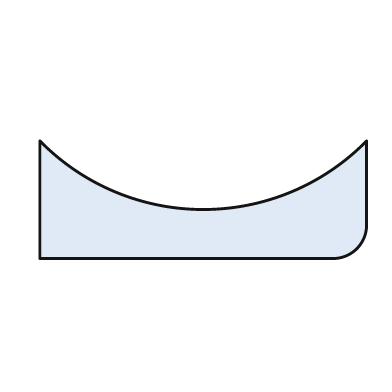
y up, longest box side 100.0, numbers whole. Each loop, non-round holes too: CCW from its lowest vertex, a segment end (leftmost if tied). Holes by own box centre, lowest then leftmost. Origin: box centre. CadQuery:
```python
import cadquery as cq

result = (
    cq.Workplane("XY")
    .moveTo(-50.0, -18.0)
    .lineTo(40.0, -18.0)
    .threePointArc((47.0, -15.0), (50.0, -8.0))
    .lineTo(50.0, 18.0)
    .threePointArc((0.0, -3.0), (-50.0, 18.0))
    .close()
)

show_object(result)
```